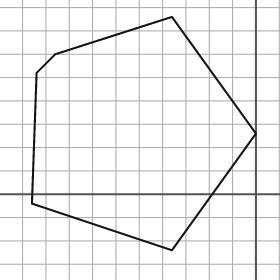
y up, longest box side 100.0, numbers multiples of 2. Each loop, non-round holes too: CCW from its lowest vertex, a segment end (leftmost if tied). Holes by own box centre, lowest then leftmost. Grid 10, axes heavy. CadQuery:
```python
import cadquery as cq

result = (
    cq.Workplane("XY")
    .moveTo(-36.0, -24.0)
    .lineTo(0.0, 26.0)
    .lineTo(-36.0, 76.0)
    .lineTo(-86.0, 60.0)
    .lineTo(-94.0, 52.0)
    .lineTo(-96.0, -4.0)
    .close()
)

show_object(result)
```